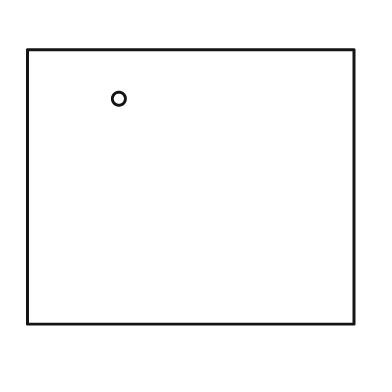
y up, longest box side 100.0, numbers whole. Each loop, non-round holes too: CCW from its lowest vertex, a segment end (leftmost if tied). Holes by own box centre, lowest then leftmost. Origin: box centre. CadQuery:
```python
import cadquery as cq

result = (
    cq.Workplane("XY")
    .moveTo(-50.0, -42.0)
    .lineTo(50.0, -42.0)
    .lineTo(50.0, 42.0)
    .lineTo(-50.0, 42.0)
    .close()
    .moveTo(-22.0, 27.0)
    .circle(2.0)
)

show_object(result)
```